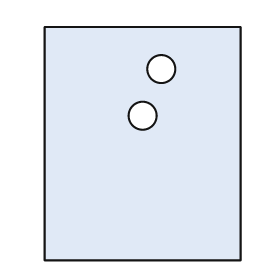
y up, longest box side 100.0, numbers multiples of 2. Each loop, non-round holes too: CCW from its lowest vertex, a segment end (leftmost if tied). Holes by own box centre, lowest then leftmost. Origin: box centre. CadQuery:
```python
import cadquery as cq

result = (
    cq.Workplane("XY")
    .moveTo(-42.0, -50.0)
    .lineTo(42.0, -50.0)
    .lineTo(42.0, 50.0)
    .lineTo(-42.0, 50.0)
    .close()
    .moveTo(0.0, 12.0)
    .circle(6.0)
    .moveTo(8.0, 32.0)
    .circle(6.0)
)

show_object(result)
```